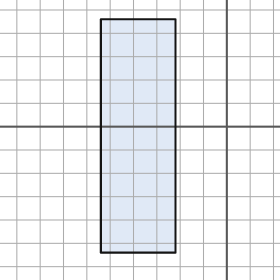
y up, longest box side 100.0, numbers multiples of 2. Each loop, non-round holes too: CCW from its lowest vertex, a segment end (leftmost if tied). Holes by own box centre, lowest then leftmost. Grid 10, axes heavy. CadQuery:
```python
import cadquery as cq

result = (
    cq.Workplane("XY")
    .moveTo(-54.0, -54.0)
    .lineTo(-22.0, -54.0)
    .lineTo(-22.0, 46.0)
    .lineTo(-54.0, 46.0)
    .close()
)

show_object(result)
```